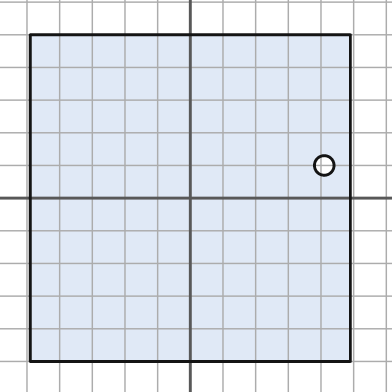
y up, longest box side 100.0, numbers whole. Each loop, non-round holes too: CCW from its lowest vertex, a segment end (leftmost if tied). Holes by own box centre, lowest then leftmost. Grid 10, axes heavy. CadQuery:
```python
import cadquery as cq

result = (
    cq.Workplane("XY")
    .moveTo(-49.0, -50.0)
    .lineTo(49.0, -50.0)
    .lineTo(49.0, 50.0)
    .lineTo(-49.0, 50.0)
    .close()
    .moveTo(41.0, 10.0)
    .circle(3.0)
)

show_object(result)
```